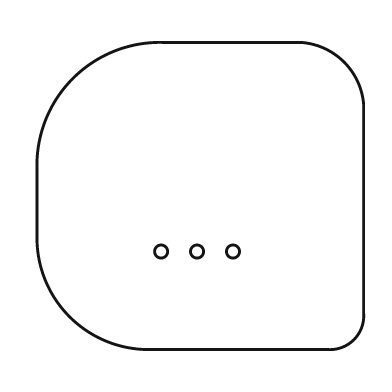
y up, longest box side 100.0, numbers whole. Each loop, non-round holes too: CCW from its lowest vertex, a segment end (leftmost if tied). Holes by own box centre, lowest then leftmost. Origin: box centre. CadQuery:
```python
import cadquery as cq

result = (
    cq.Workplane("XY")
    .moveTo(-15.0, -47.0)
    .lineTo(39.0, -47.0)
    .threePointArc((47.0, -44.0), (50.0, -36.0))
    .lineTo(50.0, 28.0)
    .threePointArc((44.0, 41.0), (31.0, 47.0))
    .lineTo(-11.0, 47.0)
    .threePointArc((-39.0, 36.0), (-50.0, 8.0))
    .lineTo(-50.0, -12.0)
    .threePointArc((-40.0, -37.0), (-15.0, -47.0))
    .close()
    .moveTo(-12.0, -17.0)
    .circle(2.0)
    .moveTo(-1.0, -17.0)
    .circle(2.0)
    .moveTo(10.0, -17.0)
    .circle(2.0)
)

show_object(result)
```